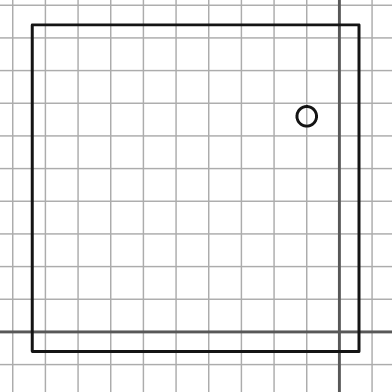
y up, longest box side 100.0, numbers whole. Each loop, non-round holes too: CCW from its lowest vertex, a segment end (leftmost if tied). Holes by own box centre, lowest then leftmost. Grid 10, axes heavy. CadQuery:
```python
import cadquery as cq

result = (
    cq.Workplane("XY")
    .moveTo(-94.0, -6.0)
    .lineTo(6.0, -6.0)
    .lineTo(6.0, 94.0)
    .lineTo(-94.0, 94.0)
    .close()
    .moveTo(-10.0, 66.0)
    .circle(3.0)
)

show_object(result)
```